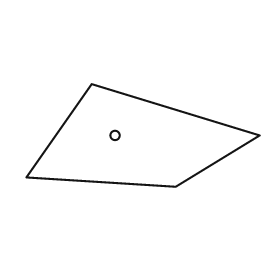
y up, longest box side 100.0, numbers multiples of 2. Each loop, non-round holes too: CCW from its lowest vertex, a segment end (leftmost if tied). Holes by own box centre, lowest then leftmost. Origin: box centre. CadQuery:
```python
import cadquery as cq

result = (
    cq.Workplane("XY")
    .moveTo(14.0, -22.0)
    .lineTo(50.0, 0.0)
    .lineTo(-22.0, 22.0)
    .lineTo(-50.0, -18.0)
    .close()
    .moveTo(-12.0, 0.0)
    .circle(2.0)
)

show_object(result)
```